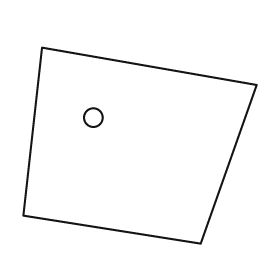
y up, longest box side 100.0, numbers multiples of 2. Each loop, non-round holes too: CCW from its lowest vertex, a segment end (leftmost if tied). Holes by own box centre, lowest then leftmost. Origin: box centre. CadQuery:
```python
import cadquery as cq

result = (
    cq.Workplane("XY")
    .moveTo(26.0, -42.0)
    .lineTo(50.0, 26.0)
    .lineTo(-42.0, 42.0)
    .lineTo(-50.0, -30.0)
    .close()
    .moveTo(-20.0, 12.0)
    .circle(4.0)
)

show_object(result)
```